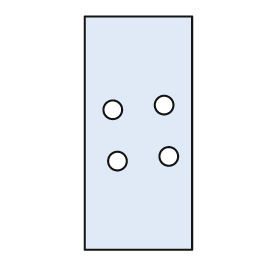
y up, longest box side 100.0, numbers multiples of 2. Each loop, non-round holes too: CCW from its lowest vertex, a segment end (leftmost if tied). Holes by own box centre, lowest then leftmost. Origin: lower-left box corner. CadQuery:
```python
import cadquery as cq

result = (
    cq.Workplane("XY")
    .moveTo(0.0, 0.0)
    .lineTo(46.0, 0.0)
    .lineTo(46.0, 100.0)
    .lineTo(0.0, 100.0)
    .close()
    .moveTo(14.0, 38.0)
    .circle(4.0)
    .moveTo(36.0, 40.0)
    .circle(4.0)
    .moveTo(12.0, 60.0)
    .circle(4.0)
    .moveTo(34.0, 62.0)
    .circle(4.0)
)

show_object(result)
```